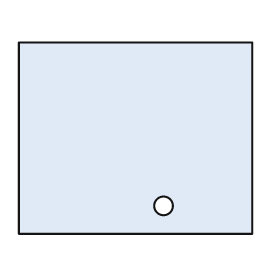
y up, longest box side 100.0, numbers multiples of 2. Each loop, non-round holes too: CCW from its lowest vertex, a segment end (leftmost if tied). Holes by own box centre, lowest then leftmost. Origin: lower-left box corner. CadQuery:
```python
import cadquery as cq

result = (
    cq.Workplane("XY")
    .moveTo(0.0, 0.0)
    .lineTo(100.0, 0.0)
    .lineTo(100.0, 82.0)
    .lineTo(0.0, 82.0)
    .close()
    .moveTo(62.0, 12.0)
    .circle(4.0)
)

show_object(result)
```